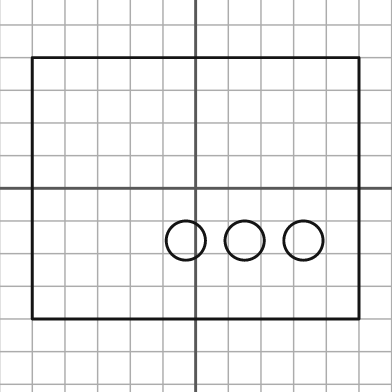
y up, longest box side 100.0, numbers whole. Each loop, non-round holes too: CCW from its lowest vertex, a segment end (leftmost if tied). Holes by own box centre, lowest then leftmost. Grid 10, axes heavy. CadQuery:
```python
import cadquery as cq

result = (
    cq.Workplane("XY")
    .moveTo(-50.0, -40.0)
    .lineTo(50.0, -40.0)
    .lineTo(50.0, 40.0)
    .lineTo(-50.0, 40.0)
    .close()
    .moveTo(-3.0, -16.0)
    .circle(6.0)
    .moveTo(15.0, -16.0)
    .circle(6.0)
    .moveTo(33.0, -16.0)
    .circle(6.0)
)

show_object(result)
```